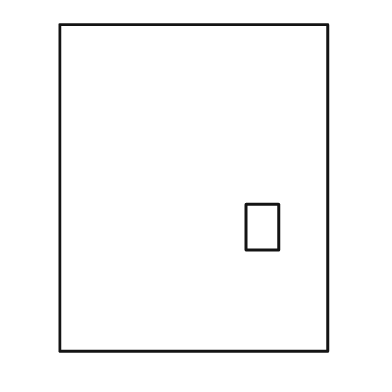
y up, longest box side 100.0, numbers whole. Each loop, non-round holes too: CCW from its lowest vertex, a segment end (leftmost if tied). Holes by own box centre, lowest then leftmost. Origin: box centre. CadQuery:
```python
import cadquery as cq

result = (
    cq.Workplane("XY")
    .moveTo(-41.0, -50.0)
    .lineTo(41.0, -50.0)
    .lineTo(41.0, 50.0)
    .lineTo(-41.0, 50.0)
    .close()
    .moveTo(16.0, -19.0)
    .lineTo(26.0, -19.0)
    .lineTo(26.0, -5.0)
    .lineTo(16.0, -5.0)
    .close()
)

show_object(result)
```